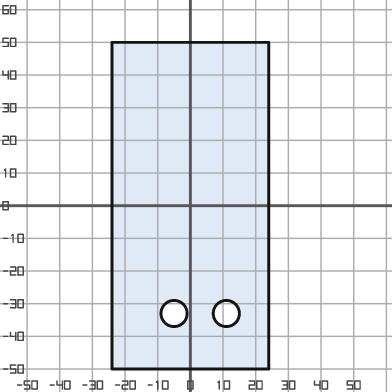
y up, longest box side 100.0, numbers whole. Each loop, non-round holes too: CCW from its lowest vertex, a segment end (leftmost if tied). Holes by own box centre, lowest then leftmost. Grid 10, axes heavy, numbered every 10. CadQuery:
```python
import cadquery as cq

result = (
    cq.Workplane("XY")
    .moveTo(-24.0, -50.0)
    .lineTo(24.0, -50.0)
    .lineTo(24.0, 50.0)
    .lineTo(-24.0, 50.0)
    .close()
    .moveTo(-5.0, -33.0)
    .circle(4.0)
    .moveTo(11.0, -33.0)
    .circle(4.0)
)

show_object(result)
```